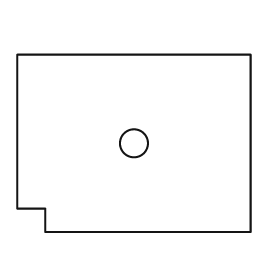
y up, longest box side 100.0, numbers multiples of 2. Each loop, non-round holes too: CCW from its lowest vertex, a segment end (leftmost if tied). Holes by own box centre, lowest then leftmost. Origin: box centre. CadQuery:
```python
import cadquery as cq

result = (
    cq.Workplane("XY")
    .moveTo(-38.0, -38.0)
    .lineTo(50.0, -38.0)
    .lineTo(50.0, 38.0)
    .lineTo(-50.0, 38.0)
    .lineTo(-50.0, -28.0)
    .lineTo(-38.0, -28.0)
    .close()
    .moveTo(0.0, 0.0)
    .circle(6.0)
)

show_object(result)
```